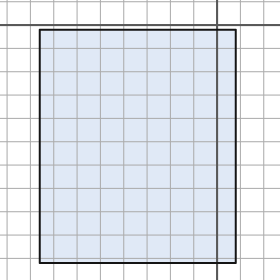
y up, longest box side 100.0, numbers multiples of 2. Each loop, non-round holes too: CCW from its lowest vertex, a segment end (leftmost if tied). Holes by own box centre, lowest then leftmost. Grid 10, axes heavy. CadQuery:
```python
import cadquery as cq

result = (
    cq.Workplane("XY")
    .moveTo(-76.0, -102.0)
    .lineTo(8.0, -102.0)
    .lineTo(8.0, -2.0)
    .lineTo(-76.0, -2.0)
    .close()
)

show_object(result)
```